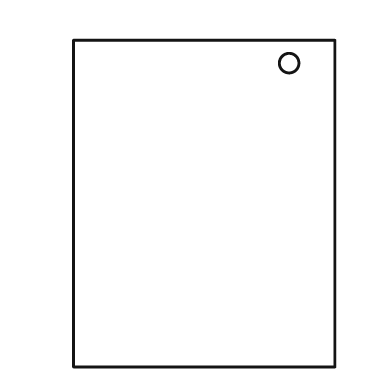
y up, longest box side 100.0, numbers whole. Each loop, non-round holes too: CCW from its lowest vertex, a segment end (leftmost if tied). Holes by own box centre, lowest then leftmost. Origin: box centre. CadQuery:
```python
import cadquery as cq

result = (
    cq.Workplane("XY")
    .moveTo(-40.0, -50.0)
    .lineTo(40.0, -50.0)
    .lineTo(40.0, 50.0)
    .lineTo(-40.0, 50.0)
    .close()
    .moveTo(26.0, 43.0)
    .circle(3.0)
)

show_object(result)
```